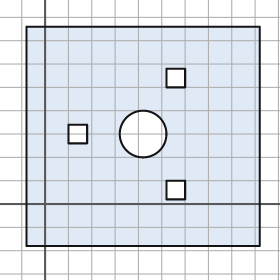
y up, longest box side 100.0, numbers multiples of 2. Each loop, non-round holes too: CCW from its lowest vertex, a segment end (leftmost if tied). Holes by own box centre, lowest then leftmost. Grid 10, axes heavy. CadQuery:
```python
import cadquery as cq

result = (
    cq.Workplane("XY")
    .moveTo(-8.0, -18.0)
    .lineTo(92.0, -18.0)
    .lineTo(92.0, 76.0)
    .lineTo(-8.0, 76.0)
    .close()
    .moveTo(52.0, 2.0)
    .lineTo(60.0, 2.0)
    .lineTo(60.0, 10.0)
    .lineTo(52.0, 10.0)
    .close()
    .moveTo(10.0, 26.0)
    .lineTo(18.0, 26.0)
    .lineTo(18.0, 34.0)
    .lineTo(10.0, 34.0)
    .close()
    .moveTo(42.0, 30.0)
    .circle(10.0)
    .moveTo(52.0, 50.0)
    .lineTo(60.0, 50.0)
    .lineTo(60.0, 58.0)
    .lineTo(52.0, 58.0)
    .close()
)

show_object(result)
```